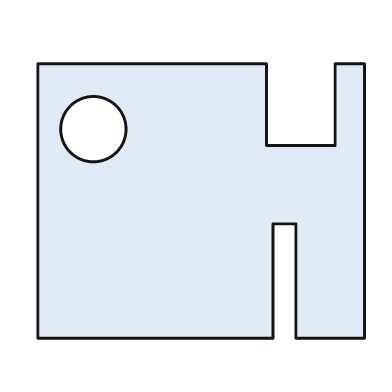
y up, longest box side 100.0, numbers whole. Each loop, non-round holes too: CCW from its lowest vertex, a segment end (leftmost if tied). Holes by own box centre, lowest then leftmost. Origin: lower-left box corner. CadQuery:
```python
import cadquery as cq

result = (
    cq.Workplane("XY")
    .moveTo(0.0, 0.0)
    .lineTo(72.0, 0.0)
    .lineTo(72.0, 35.0)
    .lineTo(79.0, 35.0)
    .lineTo(79.0, 0.0)
    .lineTo(100.0, 0.0)
    .lineTo(100.0, 84.0)
    .lineTo(91.0, 84.0)
    .lineTo(91.0, 59.0)
    .lineTo(70.0, 59.0)
    .lineTo(70.0, 84.0)
    .lineTo(0.0, 84.0)
    .close()
    .moveTo(17.0, 64.0)
    .circle(10.0)
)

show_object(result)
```